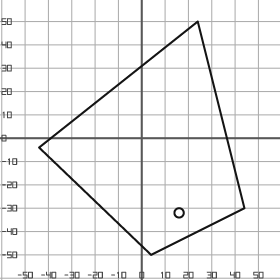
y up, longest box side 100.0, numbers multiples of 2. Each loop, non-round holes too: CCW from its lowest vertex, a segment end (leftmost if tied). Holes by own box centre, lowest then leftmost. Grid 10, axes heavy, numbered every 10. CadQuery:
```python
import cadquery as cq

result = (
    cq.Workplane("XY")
    .moveTo(4.0, -50.0)
    .lineTo(44.0, -30.0)
    .lineTo(24.0, 50.0)
    .lineTo(-44.0, -4.0)
    .close()
    .moveTo(16.0, -32.0)
    .circle(2.0)
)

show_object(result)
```